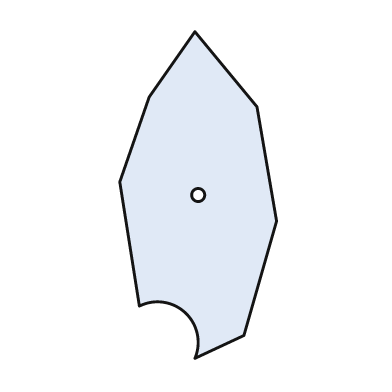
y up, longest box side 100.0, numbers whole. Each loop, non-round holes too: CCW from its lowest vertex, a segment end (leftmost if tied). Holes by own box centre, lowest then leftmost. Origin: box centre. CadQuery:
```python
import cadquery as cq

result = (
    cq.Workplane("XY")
    .moveTo(-1.0, -50.0)
    .lineTo(14.0, -43.0)
    .lineTo(24.0, -8.0)
    .lineTo(18.0, 27.0)
    .lineTo(-1.0, 50.0)
    .lineTo(-15.0, 30.0)
    .lineTo(-24.0, 4.0)
    .lineTo(-18.0, -34.0)
    .threePointArc((-4.0, -36.0), (-1.0, -50.0))
    .close()
    .moveTo(0.0, 0.0)
    .circle(2.0)
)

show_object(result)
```